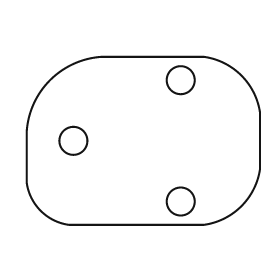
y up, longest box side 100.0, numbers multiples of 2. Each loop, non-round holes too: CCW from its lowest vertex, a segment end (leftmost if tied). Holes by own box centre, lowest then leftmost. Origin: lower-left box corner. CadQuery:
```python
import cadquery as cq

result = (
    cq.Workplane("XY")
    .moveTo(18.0, 0.0)
    .lineTo(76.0, 0.0)
    .threePointArc((92.0, 8.0), (100.0, 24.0))
    .lineTo(100.0, 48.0)
    .threePointArc((92.0, 64.0), (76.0, 72.0))
    .lineTo(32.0, 72.0)
    .threePointArc((10.0, 62.0), (0.0, 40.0))
    .lineTo(0.0, 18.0)
    .threePointArc((6.0, 6.0), (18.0, 0.0))
    .close()
    .moveTo(66.0, 10.0)
    .circle(6.0)
    .moveTo(20.0, 36.0)
    .circle(6.0)
    .moveTo(66.0, 62.0)
    .circle(6.0)
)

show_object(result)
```